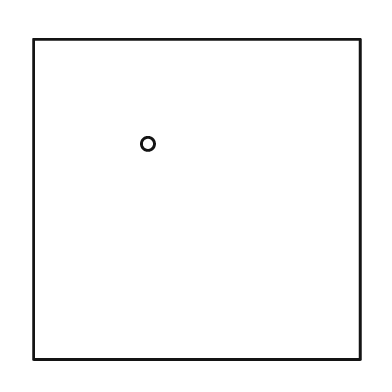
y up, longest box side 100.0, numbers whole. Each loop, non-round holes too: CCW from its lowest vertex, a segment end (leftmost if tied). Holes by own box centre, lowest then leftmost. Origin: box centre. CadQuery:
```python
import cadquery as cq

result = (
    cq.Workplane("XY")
    .moveTo(-50.0, -49.0)
    .lineTo(50.0, -49.0)
    .lineTo(50.0, 49.0)
    .lineTo(-50.0, 49.0)
    .close()
    .moveTo(-15.0, 17.0)
    .circle(2.0)
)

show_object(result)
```